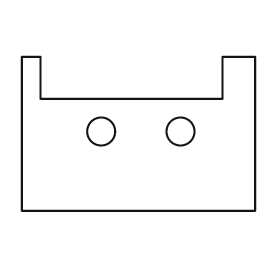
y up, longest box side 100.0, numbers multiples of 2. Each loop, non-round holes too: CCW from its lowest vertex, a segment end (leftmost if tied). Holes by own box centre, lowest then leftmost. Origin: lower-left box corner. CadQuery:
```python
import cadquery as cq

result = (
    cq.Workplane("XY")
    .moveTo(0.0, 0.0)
    .lineTo(100.0, 0.0)
    .lineTo(100.0, 66.0)
    .lineTo(86.0, 66.0)
    .lineTo(86.0, 48.0)
    .lineTo(8.0, 48.0)
    .lineTo(8.0, 66.0)
    .lineTo(0.0, 66.0)
    .close()
    .moveTo(34.0, 34.0)
    .circle(6.0)
    .moveTo(68.0, 34.0)
    .circle(6.0)
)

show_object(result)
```